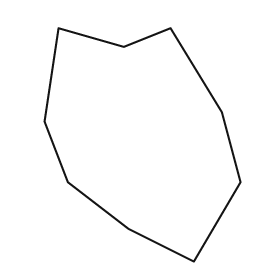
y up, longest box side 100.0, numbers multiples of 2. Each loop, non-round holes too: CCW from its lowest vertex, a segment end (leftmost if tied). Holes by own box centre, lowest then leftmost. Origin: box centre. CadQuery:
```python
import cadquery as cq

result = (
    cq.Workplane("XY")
    .moveTo(22.0, -50.0)
    .lineTo(42.0, -16.0)
    .lineTo(34.0, 14.0)
    .lineTo(12.0, 50.0)
    .lineTo(-8.0, 42.0)
    .lineTo(-36.0, 50.0)
    .lineTo(-42.0, 10.0)
    .lineTo(-32.0, -16.0)
    .lineTo(-6.0, -36.0)
    .close()
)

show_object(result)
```